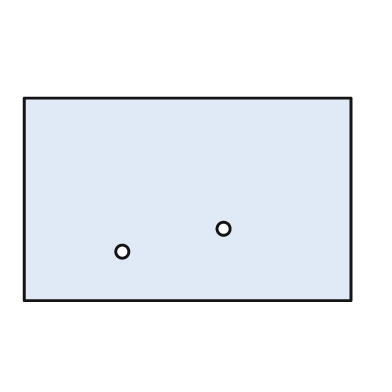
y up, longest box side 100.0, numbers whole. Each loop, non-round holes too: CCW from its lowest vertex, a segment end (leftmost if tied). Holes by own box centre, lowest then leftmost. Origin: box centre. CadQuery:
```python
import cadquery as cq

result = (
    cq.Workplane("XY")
    .moveTo(-50.0, -31.0)
    .lineTo(50.0, -31.0)
    .lineTo(50.0, 31.0)
    .lineTo(-50.0, 31.0)
    .close()
    .moveTo(-20.0, -16.0)
    .circle(2.0)
    .moveTo(11.0, -9.0)
    .circle(2.0)
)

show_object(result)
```